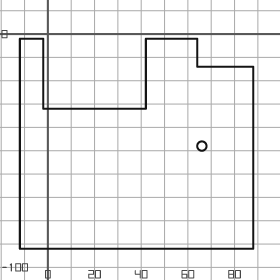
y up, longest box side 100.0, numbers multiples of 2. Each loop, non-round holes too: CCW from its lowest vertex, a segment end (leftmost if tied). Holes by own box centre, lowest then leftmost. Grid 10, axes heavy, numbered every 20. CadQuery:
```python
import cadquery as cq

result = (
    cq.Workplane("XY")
    .moveTo(-12.0, -92.0)
    .lineTo(88.0, -92.0)
    .lineTo(88.0, -14.0)
    .lineTo(64.0, -14.0)
    .lineTo(64.0, -2.0)
    .lineTo(42.0, -2.0)
    .lineTo(42.0, -32.0)
    .lineTo(-2.0, -32.0)
    .lineTo(-2.0, -2.0)
    .lineTo(-12.0, -2.0)
    .close()
    .moveTo(66.0, -48.0)
    .circle(2.0)
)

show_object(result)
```